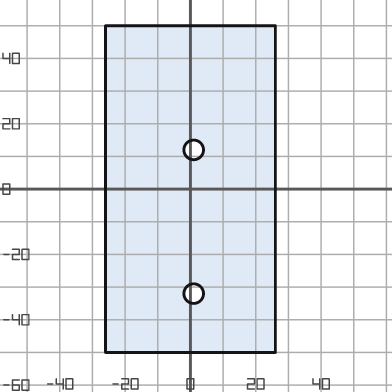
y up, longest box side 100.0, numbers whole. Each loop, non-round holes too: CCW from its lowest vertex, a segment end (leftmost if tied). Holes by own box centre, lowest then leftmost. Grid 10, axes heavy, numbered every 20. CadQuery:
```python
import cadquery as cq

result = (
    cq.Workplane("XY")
    .moveTo(-26.0, -50.0)
    .lineTo(26.0, -50.0)
    .lineTo(26.0, 50.0)
    .lineTo(-26.0, 50.0)
    .close()
    .moveTo(1.0, -32.0)
    .circle(3.0)
    .moveTo(1.0, 12.0)
    .circle(3.0)
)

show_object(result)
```